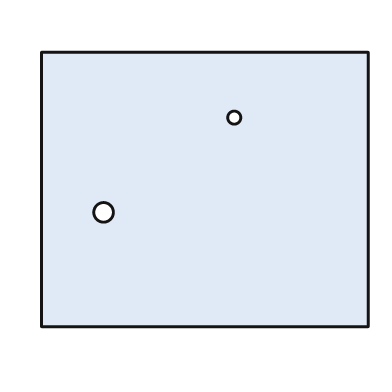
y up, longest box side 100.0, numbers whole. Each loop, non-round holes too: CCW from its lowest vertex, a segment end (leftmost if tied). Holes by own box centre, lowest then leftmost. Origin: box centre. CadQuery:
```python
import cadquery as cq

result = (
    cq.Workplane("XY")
    .moveTo(-50.0, -42.0)
    .lineTo(50.0, -42.0)
    .lineTo(50.0, 42.0)
    .lineTo(-50.0, 42.0)
    .close()
    .moveTo(-31.0, -7.0)
    .circle(3.0)
    .moveTo(9.0, 22.0)
    .circle(2.0)
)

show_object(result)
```